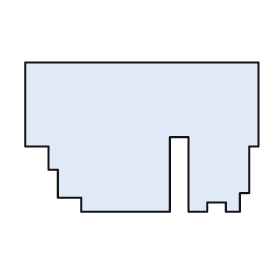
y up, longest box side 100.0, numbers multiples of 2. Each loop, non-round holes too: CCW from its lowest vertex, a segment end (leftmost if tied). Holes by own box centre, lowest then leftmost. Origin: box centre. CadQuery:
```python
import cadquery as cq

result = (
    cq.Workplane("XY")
    .moveTo(-26.0, -32.0)
    .lineTo(12.0, -32.0)
    .lineTo(12.0, 0.0)
    .lineTo(20.0, 0.0)
    .lineTo(20.0, -32.0)
    .lineTo(28.0, -32.0)
    .lineTo(28.0, -28.0)
    .lineTo(36.0, -28.0)
    .lineTo(36.0, -32.0)
    .lineTo(42.0, -32.0)
    .lineTo(42.0, -24.0)
    .lineTo(46.0, -24.0)
    .lineTo(46.0, -4.0)
    .lineTo(50.0, -4.0)
    .lineTo(50.0, 32.0)
    .lineTo(-50.0, 32.0)
    .lineTo(-50.0, -4.0)
    .lineTo(-40.0, -4.0)
    .lineTo(-40.0, -14.0)
    .lineTo(-36.0, -14.0)
    .lineTo(-36.0, -26.0)
    .lineTo(-26.0, -26.0)
    .close()
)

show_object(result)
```